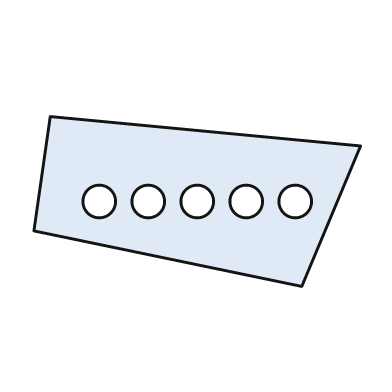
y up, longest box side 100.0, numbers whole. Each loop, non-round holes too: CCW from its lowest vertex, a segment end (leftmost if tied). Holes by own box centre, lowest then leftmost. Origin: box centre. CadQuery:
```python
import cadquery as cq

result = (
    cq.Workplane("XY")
    .moveTo(32.0, -26.0)
    .lineTo(50.0, 17.0)
    .lineTo(-45.0, 26.0)
    .lineTo(-50.0, -9.0)
    .close()
    .moveTo(-30.0, 0.0)
    .circle(5.0)
    .moveTo(-15.0, 0.0)
    .circle(5.0)
    .moveTo(0.0, 0.0)
    .circle(5.0)
    .moveTo(15.0, 0.0)
    .circle(5.0)
    .moveTo(30.0, 0.0)
    .circle(5.0)
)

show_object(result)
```